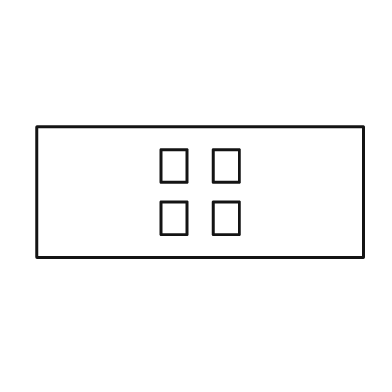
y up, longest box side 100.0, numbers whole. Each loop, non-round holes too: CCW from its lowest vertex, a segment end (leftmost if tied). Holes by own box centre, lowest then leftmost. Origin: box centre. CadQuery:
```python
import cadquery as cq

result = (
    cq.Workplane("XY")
    .moveTo(-50.0, -20.0)
    .lineTo(50.0, -20.0)
    .lineTo(50.0, 20.0)
    .lineTo(-50.0, 20.0)
    .close()
    .moveTo(-12.0, -13.0)
    .lineTo(-4.0, -13.0)
    .lineTo(-4.0, -3.0)
    .lineTo(-12.0, -3.0)
    .close()
    .moveTo(4.0, -13.0)
    .lineTo(12.0, -13.0)
    .lineTo(12.0, -3.0)
    .lineTo(4.0, -3.0)
    .close()
    .moveTo(-12.0, 3.0)
    .lineTo(-4.0, 3.0)
    .lineTo(-4.0, 13.0)
    .lineTo(-12.0, 13.0)
    .close()
    .moveTo(4.0, 3.0)
    .lineTo(12.0, 3.0)
    .lineTo(12.0, 13.0)
    .lineTo(4.0, 13.0)
    .close()
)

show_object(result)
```